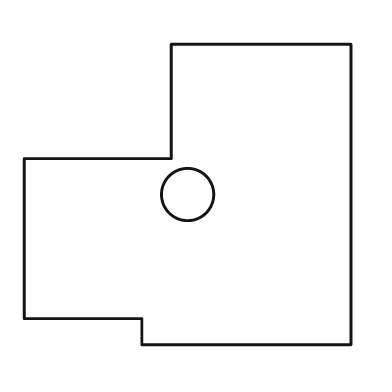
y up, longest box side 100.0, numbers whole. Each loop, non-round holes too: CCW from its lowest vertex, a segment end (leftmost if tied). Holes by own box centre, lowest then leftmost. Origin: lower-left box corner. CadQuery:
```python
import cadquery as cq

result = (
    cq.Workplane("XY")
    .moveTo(36.0, 0.0)
    .lineTo(100.0, 0.0)
    .lineTo(100.0, 92.0)
    .lineTo(45.0, 92.0)
    .lineTo(45.0, 57.0)
    .lineTo(0.0, 57.0)
    .lineTo(0.0, 8.0)
    .lineTo(36.0, 8.0)
    .close()
    .moveTo(50.0, 46.0)
    .circle(8.0)
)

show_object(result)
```